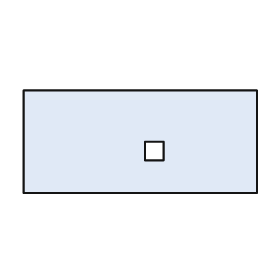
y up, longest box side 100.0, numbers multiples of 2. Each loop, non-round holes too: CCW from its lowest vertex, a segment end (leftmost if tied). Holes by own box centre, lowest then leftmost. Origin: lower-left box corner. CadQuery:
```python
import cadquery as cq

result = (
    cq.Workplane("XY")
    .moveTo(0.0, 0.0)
    .lineTo(100.0, 0.0)
    .lineTo(100.0, 44.0)
    .lineTo(0.0, 44.0)
    .close()
    .moveTo(52.0, 14.0)
    .lineTo(60.0, 14.0)
    .lineTo(60.0, 22.0)
    .lineTo(52.0, 22.0)
    .close()
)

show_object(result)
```